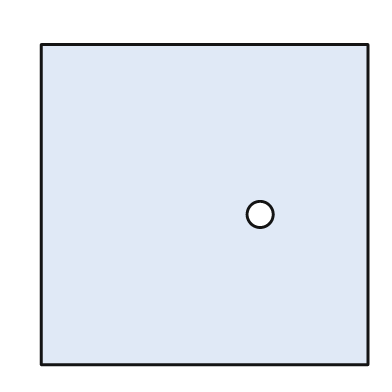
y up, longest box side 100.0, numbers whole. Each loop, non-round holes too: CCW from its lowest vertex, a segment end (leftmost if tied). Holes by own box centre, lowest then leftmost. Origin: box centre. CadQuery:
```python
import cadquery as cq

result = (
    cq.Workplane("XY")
    .moveTo(-50.0, -49.0)
    .lineTo(50.0, -49.0)
    .lineTo(50.0, 49.0)
    .lineTo(-50.0, 49.0)
    .close()
    .moveTo(17.0, -3.0)
    .circle(4.0)
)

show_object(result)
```